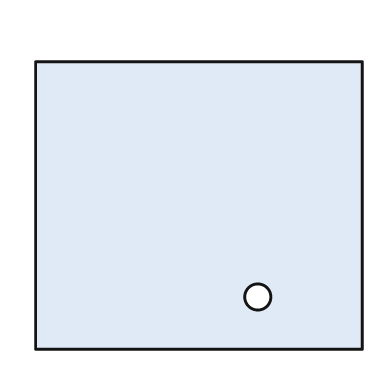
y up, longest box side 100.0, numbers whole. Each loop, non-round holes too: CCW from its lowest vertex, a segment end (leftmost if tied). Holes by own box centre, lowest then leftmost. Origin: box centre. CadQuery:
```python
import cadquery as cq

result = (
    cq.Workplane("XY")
    .moveTo(-50.0, -44.0)
    .lineTo(50.0, -44.0)
    .lineTo(50.0, 44.0)
    .lineTo(-50.0, 44.0)
    .close()
    .moveTo(18.0, -28.0)
    .circle(4.0)
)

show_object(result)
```